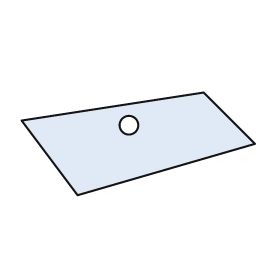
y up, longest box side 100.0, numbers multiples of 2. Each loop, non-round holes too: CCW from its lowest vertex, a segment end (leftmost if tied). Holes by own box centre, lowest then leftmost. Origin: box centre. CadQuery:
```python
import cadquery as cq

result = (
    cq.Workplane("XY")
    .moveTo(-26.0, -22.0)
    .lineTo(50.0, 0.0)
    .lineTo(28.0, 22.0)
    .lineTo(-50.0, 10.0)
    .close()
    .moveTo(-4.0, 8.0)
    .circle(4.0)
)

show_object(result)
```